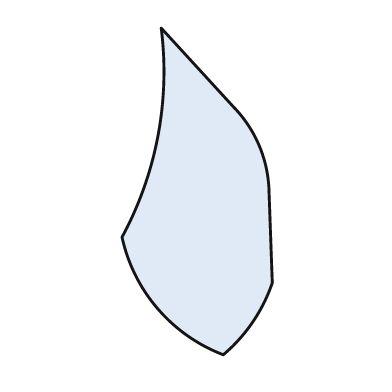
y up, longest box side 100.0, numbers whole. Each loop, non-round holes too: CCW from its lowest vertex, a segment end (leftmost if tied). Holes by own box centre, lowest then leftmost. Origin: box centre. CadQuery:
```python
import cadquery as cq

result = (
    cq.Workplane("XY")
    .moveTo(8.0, -50.0)
    .threePointArc((17.0, -40.0), (23.0, -28.0))
    .lineTo(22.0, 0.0)
    .threePointArc((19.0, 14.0), (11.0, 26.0))
    .lineTo(-11.0, 50.0)
    .threePointArc((-12.0, 17.0), (-23.0, -14.0))
    .threePointArc((-12.0, -36.0), (8.0, -50.0))
    .close()
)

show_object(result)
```